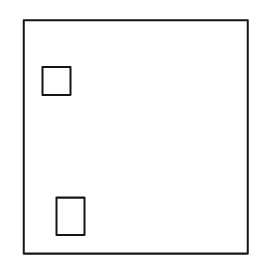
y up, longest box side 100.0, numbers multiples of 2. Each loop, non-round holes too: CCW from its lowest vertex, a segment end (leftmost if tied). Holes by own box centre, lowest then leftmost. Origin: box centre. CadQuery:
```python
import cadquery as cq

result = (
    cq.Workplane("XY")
    .moveTo(-48.0, -50.0)
    .lineTo(48.0, -50.0)
    .lineTo(48.0, 50.0)
    .lineTo(-48.0, 50.0)
    .close()
    .moveTo(-34.0, -42.0)
    .lineTo(-22.0, -42.0)
    .lineTo(-22.0, -26.0)
    .lineTo(-34.0, -26.0)
    .close()
    .moveTo(-40.0, 18.0)
    .lineTo(-28.0, 18.0)
    .lineTo(-28.0, 30.0)
    .lineTo(-40.0, 30.0)
    .close()
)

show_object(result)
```